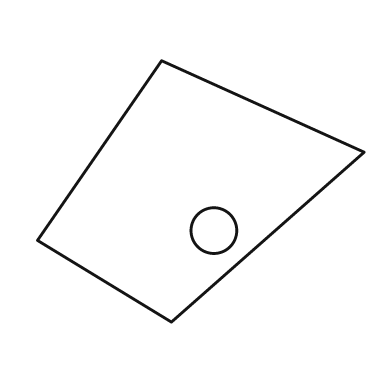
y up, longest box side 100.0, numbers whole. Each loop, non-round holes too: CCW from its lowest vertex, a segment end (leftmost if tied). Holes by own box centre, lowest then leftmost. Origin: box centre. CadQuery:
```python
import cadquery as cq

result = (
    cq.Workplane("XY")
    .moveTo(-9.0, -40.0)
    .lineTo(50.0, 12.0)
    .lineTo(-12.0, 40.0)
    .lineTo(-50.0, -15.0)
    .close()
    .moveTo(4.0, -12.0)
    .circle(7.0)
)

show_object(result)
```